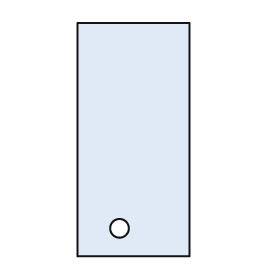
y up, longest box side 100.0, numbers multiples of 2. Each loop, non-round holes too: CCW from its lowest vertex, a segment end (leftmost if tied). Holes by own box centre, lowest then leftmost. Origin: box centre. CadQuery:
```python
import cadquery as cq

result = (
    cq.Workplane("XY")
    .moveTo(-24.0, -50.0)
    .lineTo(24.0, -50.0)
    .lineTo(24.0, 50.0)
    .lineTo(-24.0, 50.0)
    .close()
    .moveTo(-6.0, -38.0)
    .circle(4.0)
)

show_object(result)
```